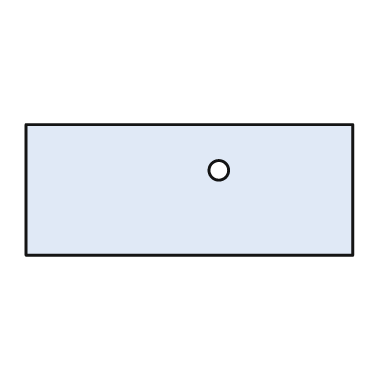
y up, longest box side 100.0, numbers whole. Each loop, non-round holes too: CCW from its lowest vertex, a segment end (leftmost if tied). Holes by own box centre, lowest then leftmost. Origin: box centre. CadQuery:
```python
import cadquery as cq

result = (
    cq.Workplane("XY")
    .moveTo(-50.0, -20.0)
    .lineTo(50.0, -20.0)
    .lineTo(50.0, 20.0)
    .lineTo(-50.0, 20.0)
    .close()
    .moveTo(9.0, 6.0)
    .circle(3.0)
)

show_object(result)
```